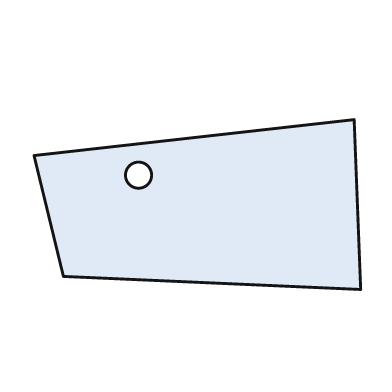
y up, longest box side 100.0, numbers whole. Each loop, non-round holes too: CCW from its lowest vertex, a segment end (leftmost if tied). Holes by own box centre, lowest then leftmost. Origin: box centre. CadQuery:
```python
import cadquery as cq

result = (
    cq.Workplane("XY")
    .moveTo(50.0, -26.0)
    .lineTo(48.0, 26.0)
    .lineTo(-50.0, 15.0)
    .lineTo(-41.0, -22.0)
    .close()
    .moveTo(-18.0, 9.0)
    .circle(4.0)
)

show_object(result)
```